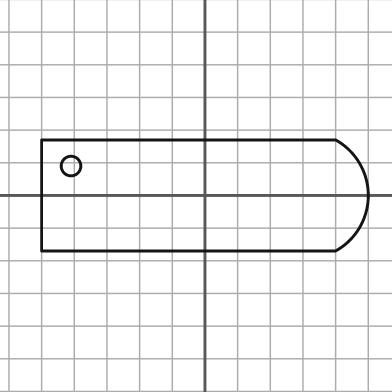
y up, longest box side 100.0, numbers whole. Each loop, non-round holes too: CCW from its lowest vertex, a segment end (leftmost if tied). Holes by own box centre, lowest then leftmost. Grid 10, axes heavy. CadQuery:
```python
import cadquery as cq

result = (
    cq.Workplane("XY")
    .moveTo(-50.0, -17.0)
    .lineTo(40.0, -17.0)
    .threePointArc((50.0, 0.0), (40.0, 17.0))
    .lineTo(-50.0, 17.0)
    .close()
    .moveTo(-41.0, 9.0)
    .circle(3.0)
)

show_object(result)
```